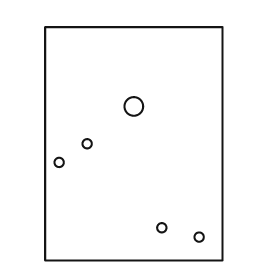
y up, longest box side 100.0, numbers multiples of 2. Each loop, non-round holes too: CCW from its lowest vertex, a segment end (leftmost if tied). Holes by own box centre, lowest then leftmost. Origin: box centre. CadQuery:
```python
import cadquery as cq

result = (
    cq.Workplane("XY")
    .moveTo(-38.0, -50.0)
    .lineTo(38.0, -50.0)
    .lineTo(38.0, 50.0)
    .lineTo(-38.0, 50.0)
    .close()
    .moveTo(28.0, -40.0)
    .circle(2.0)
    .moveTo(12.0, -36.0)
    .circle(2.0)
    .moveTo(-32.0, -8.0)
    .circle(2.0)
    .moveTo(-20.0, 0.0)
    .circle(2.0)
    .moveTo(0.0, 16.0)
    .circle(4.0)
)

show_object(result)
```